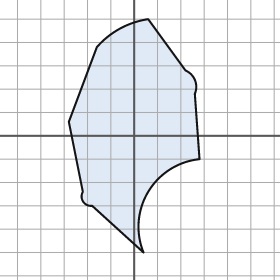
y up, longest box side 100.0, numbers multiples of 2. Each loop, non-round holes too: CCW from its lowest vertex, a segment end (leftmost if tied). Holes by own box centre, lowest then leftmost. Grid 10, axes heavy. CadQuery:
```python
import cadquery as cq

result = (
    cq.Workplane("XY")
    .moveTo(4.0, -50.0)
    .threePointArc((6.0, -24.0), (28.0, -10.0))
    .lineTo(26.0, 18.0)
    .threePointArc((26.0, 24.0), (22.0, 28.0))
    .lineTo(6.0, 50.0)
    .threePointArc((-6.0, 46.0), (-16.0, 38.0))
    .lineTo(-28.0, 6.0)
    .lineTo(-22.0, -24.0)
    .threePointArc((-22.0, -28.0), (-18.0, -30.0))
    .close()
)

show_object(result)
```